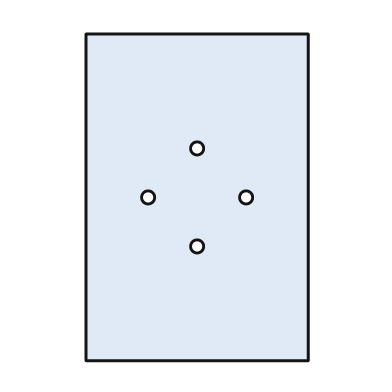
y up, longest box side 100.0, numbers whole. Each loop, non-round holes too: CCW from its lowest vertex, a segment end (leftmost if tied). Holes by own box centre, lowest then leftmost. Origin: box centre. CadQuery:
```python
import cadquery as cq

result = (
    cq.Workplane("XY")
    .moveTo(-34.0, -50.0)
    .lineTo(34.0, -50.0)
    .lineTo(34.0, 50.0)
    .lineTo(-34.0, 50.0)
    .close()
    .moveTo(0.0, -15.0)
    .circle(2.0)
    .moveTo(-15.0, 0.0)
    .circle(2.0)
    .moveTo(15.0, 0.0)
    .circle(2.0)
    .moveTo(0.0, 15.0)
    .circle(2.0)
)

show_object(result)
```